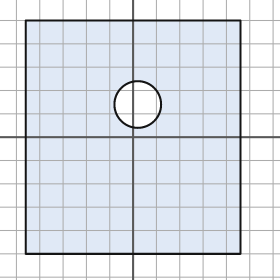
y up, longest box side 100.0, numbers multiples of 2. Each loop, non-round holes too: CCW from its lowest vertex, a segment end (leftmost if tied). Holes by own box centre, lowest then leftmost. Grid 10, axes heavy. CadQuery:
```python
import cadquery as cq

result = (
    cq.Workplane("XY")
    .moveTo(-46.0, -50.0)
    .lineTo(46.0, -50.0)
    .lineTo(46.0, 50.0)
    .lineTo(-46.0, 50.0)
    .close()
    .moveTo(2.0, 14.0)
    .circle(10.0)
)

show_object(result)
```